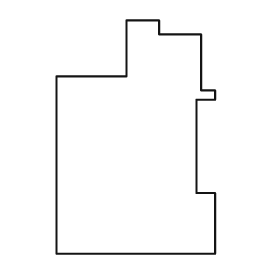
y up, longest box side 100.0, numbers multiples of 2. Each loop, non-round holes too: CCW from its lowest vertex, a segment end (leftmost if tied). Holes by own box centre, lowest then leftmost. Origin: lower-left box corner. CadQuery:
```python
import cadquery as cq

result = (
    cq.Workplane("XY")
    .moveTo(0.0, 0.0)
    .lineTo(68.0, 0.0)
    .lineTo(68.0, 26.0)
    .lineTo(60.0, 26.0)
    .lineTo(60.0, 66.0)
    .lineTo(68.0, 66.0)
    .lineTo(68.0, 70.0)
    .lineTo(62.0, 70.0)
    .lineTo(62.0, 94.0)
    .lineTo(44.0, 94.0)
    .lineTo(44.0, 100.0)
    .lineTo(30.0, 100.0)
    .lineTo(30.0, 76.0)
    .lineTo(0.0, 76.0)
    .close()
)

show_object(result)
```